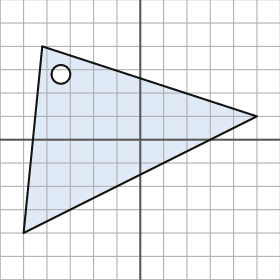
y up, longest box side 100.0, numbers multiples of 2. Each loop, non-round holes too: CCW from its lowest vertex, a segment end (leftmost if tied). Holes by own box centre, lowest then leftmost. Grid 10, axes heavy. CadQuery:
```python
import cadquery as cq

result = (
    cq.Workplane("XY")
    .moveTo(-50.0, -40.0)
    .lineTo(50.0, 10.0)
    .lineTo(-42.0, 40.0)
    .close()
    .moveTo(-34.0, 28.0)
    .circle(4.0)
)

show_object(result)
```